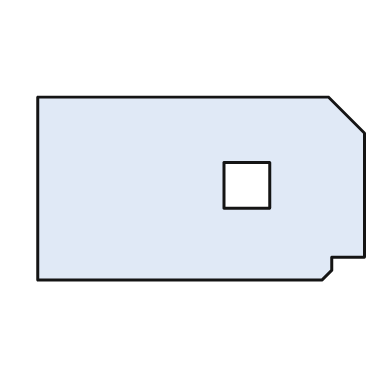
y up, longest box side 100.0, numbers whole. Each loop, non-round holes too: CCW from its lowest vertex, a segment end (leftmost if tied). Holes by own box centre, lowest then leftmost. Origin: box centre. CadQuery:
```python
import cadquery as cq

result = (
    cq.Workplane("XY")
    .moveTo(-50.0, -28.0)
    .lineTo(37.0, -28.0)
    .lineTo(40.0, -25.0)
    .lineTo(40.0, -21.0)
    .lineTo(50.0, -21.0)
    .lineTo(50.0, 17.0)
    .lineTo(39.0, 28.0)
    .lineTo(-50.0, 28.0)
    .close()
    .moveTo(7.0, -6.0)
    .lineTo(21.0, -6.0)
    .lineTo(21.0, 8.0)
    .lineTo(7.0, 8.0)
    .close()
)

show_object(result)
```